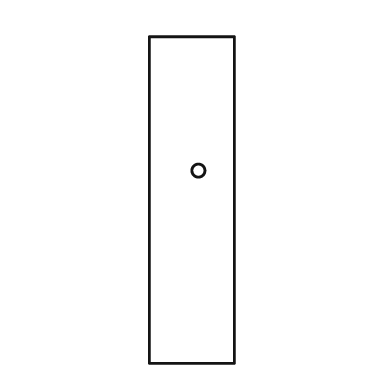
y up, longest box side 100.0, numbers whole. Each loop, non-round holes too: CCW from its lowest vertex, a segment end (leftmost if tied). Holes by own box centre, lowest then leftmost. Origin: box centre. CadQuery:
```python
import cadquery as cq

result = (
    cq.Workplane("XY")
    .moveTo(-13.0, -50.0)
    .lineTo(13.0, -50.0)
    .lineTo(13.0, 50.0)
    .lineTo(-13.0, 50.0)
    .close()
    .moveTo(2.0, 9.0)
    .circle(2.0)
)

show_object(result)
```